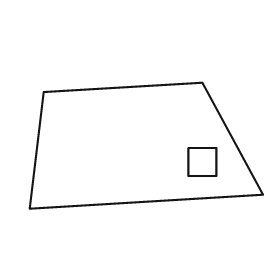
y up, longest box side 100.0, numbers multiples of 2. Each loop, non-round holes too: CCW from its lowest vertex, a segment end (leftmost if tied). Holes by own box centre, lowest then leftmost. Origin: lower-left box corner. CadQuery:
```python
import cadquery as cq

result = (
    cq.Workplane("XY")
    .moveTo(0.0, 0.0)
    .lineTo(100.0, 6.0)
    .lineTo(74.0, 54.0)
    .lineTo(6.0, 50.0)
    .close()
    .moveTo(68.0, 14.0)
    .lineTo(80.0, 14.0)
    .lineTo(80.0, 26.0)
    .lineTo(68.0, 26.0)
    .close()
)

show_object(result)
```